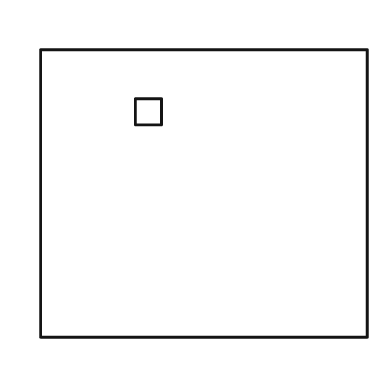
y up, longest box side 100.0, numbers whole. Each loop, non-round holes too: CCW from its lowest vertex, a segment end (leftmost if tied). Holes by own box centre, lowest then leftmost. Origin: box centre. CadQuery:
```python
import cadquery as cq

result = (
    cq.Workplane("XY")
    .moveTo(-50.0, -44.0)
    .lineTo(50.0, -44.0)
    .lineTo(50.0, 44.0)
    .lineTo(-50.0, 44.0)
    .close()
    .moveTo(-21.0, 21.0)
    .lineTo(-13.0, 21.0)
    .lineTo(-13.0, 29.0)
    .lineTo(-21.0, 29.0)
    .close()
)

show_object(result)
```